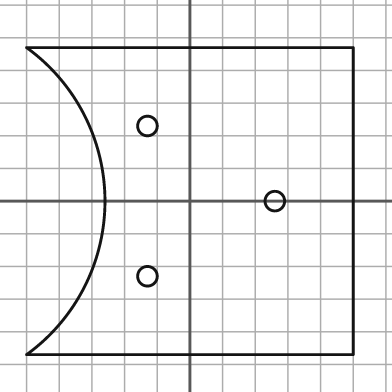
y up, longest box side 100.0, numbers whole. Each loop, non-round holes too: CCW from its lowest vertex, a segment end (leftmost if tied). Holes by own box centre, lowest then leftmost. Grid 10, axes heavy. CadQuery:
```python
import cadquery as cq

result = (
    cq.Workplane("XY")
    .moveTo(-50.0, -47.0)
    .lineTo(50.0, -47.0)
    .lineTo(50.0, 47.0)
    .lineTo(-50.0, 47.0)
    .threePointArc((-26.0, 0.0), (-50.0, -47.0))
    .close()
    .moveTo(-13.0, -23.0)
    .circle(3.0)
    .moveTo(26.0, 0.0)
    .circle(3.0)
    .moveTo(-13.0, 23.0)
    .circle(3.0)
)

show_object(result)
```